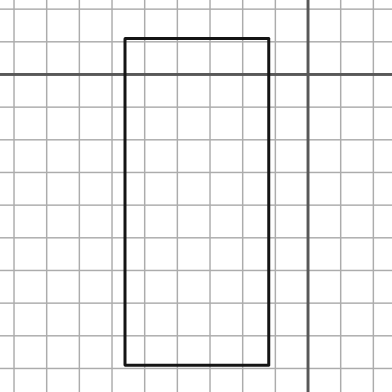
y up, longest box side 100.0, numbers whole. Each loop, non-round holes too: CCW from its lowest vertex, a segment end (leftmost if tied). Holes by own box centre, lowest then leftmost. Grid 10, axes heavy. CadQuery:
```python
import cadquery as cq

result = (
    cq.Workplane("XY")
    .moveTo(-56.0, -89.0)
    .lineTo(-12.0, -89.0)
    .lineTo(-12.0, 11.0)
    .lineTo(-56.0, 11.0)
    .close()
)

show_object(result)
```